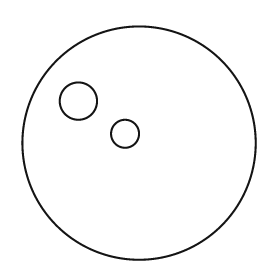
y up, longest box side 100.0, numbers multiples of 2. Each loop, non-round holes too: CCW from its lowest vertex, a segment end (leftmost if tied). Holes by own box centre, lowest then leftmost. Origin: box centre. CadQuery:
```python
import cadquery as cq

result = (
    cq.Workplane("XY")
    .moveTo(0.0, 0.0)
    .circle(50.0)
    .moveTo(-6.0, 4.0)
    .circle(6.0)
    .moveTo(-26.0, 18.0)
    .circle(8.0)
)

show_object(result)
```